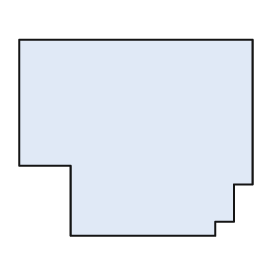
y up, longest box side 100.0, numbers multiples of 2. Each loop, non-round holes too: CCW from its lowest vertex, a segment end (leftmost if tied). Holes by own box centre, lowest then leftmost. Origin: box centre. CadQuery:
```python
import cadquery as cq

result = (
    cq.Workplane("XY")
    .moveTo(-28.0, -42.0)
    .lineTo(34.0, -42.0)
    .lineTo(34.0, -36.0)
    .lineTo(42.0, -36.0)
    .lineTo(42.0, -20.0)
    .lineTo(50.0, -20.0)
    .lineTo(50.0, 42.0)
    .lineTo(-50.0, 42.0)
    .lineTo(-50.0, -12.0)
    .lineTo(-28.0, -12.0)
    .close()
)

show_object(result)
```